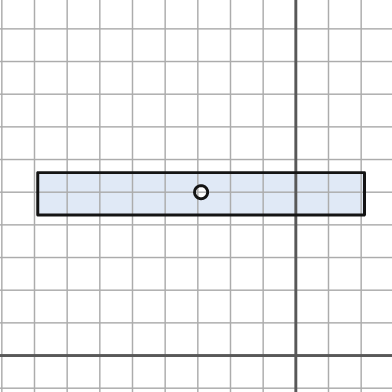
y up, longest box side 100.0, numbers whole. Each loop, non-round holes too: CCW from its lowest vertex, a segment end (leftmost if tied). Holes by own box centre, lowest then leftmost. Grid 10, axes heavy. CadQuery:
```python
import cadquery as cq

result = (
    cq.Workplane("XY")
    .moveTo(-79.0, 43.0)
    .lineTo(21.0, 43.0)
    .lineTo(21.0, 56.0)
    .lineTo(-79.0, 56.0)
    .close()
    .moveTo(-29.0, 50.0)
    .circle(2.0)
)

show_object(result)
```